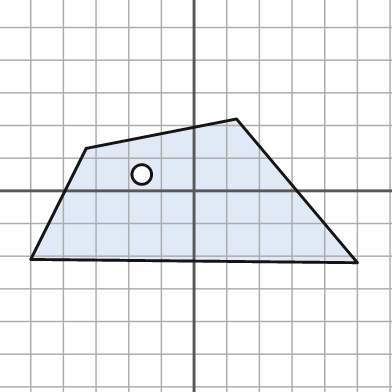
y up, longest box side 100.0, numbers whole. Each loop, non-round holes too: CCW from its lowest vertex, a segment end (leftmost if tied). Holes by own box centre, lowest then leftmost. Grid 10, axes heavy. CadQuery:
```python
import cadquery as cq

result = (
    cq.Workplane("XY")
    .moveTo(50.0, -22.0)
    .lineTo(13.0, 22.0)
    .lineTo(-33.0, 13.0)
    .lineTo(-50.0, -21.0)
    .close()
    .moveTo(-16.0, 5.0)
    .circle(3.0)
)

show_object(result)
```